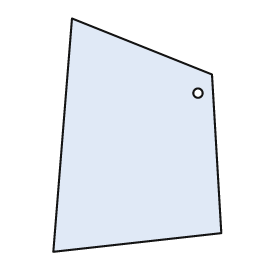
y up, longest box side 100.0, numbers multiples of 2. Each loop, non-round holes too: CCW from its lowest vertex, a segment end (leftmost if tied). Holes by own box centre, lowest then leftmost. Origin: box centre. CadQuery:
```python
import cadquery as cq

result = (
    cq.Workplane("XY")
    .moveTo(-36.0, -50.0)
    .lineTo(36.0, -42.0)
    .lineTo(32.0, 26.0)
    .lineTo(-28.0, 50.0)
    .close()
    .moveTo(26.0, 18.0)
    .circle(2.0)
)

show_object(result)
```